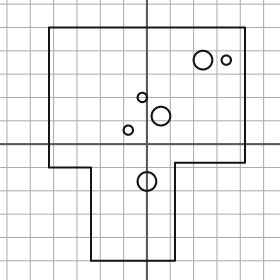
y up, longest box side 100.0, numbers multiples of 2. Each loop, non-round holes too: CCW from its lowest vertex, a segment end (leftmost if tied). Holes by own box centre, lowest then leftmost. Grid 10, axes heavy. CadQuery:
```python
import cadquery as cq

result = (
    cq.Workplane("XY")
    .moveTo(-24.0, -50.0)
    .lineTo(12.0, -50.0)
    .lineTo(12.0, -8.0)
    .lineTo(42.0, -8.0)
    .lineTo(42.0, 50.0)
    .lineTo(-42.0, 50.0)
    .lineTo(-42.0, -10.0)
    .lineTo(-24.0, -10.0)
    .close()
    .moveTo(0.0, -16.0)
    .circle(4.0)
    .moveTo(-8.0, 6.0)
    .circle(2.0)
    .moveTo(6.0, 12.0)
    .circle(4.0)
    .moveTo(-2.0, 20.0)
    .circle(2.0)
    .moveTo(24.0, 36.0)
    .circle(4.0)
    .moveTo(34.0, 36.0)
    .circle(2.0)
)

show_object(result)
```